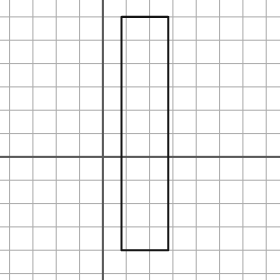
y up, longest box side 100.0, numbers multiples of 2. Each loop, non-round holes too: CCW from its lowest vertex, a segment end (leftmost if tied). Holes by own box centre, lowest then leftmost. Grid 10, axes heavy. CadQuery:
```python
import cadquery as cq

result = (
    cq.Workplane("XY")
    .moveTo(8.0, -40.0)
    .lineTo(28.0, -40.0)
    .lineTo(28.0, 60.0)
    .lineTo(8.0, 60.0)
    .close()
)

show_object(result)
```